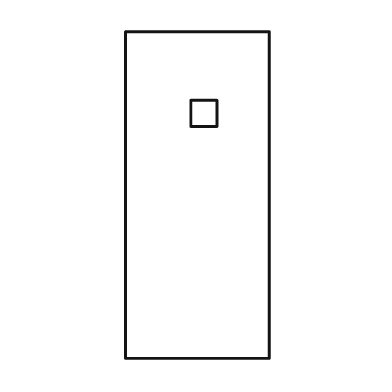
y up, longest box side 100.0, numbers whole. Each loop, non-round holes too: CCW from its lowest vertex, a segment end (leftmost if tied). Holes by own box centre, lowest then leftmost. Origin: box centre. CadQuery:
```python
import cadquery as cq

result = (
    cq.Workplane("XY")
    .moveTo(-22.0, -50.0)
    .lineTo(22.0, -50.0)
    .lineTo(22.0, 50.0)
    .lineTo(-22.0, 50.0)
    .close()
    .moveTo(-2.0, 21.0)
    .lineTo(6.0, 21.0)
    .lineTo(6.0, 29.0)
    .lineTo(-2.0, 29.0)
    .close()
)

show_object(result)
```